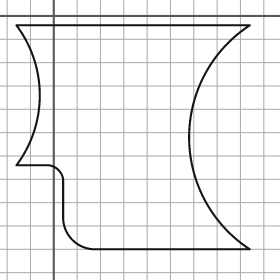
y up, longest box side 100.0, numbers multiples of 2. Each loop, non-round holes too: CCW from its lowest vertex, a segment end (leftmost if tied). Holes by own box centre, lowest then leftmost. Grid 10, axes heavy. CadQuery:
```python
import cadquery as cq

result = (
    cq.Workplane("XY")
    .moveTo(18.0, -100.0)
    .lineTo(84.0, -100.0)
    .threePointArc((58.0, -52.0), (84.0, -4.0))
    .lineTo(-16.0, -4.0)
    .threePointArc((-6.0, -34.0), (-16.0, -64.0))
    .lineTo(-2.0, -64.0)
    .threePointArc((2.0, -66.0), (4.0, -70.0))
    .lineTo(4.0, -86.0)
    .threePointArc((8.0, -96.0), (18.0, -100.0))
    .close()
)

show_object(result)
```